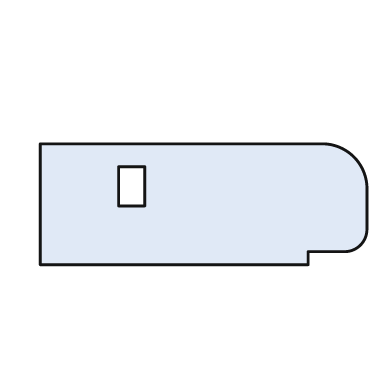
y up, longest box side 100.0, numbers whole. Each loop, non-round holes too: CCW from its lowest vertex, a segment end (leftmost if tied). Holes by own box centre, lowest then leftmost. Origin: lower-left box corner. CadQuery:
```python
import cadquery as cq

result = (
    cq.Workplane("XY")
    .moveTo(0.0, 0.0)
    .lineTo(82.0, 0.0)
    .lineTo(82.0, 4.0)
    .lineTo(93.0, 4.0)
    .threePointArc((98.0, 6.0), (100.0, 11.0))
    .lineTo(100.0, 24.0)
    .threePointArc((96.0, 33.0), (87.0, 37.0))
    .lineTo(0.0, 37.0)
    .close()
    .moveTo(24.0, 18.0)
    .lineTo(32.0, 18.0)
    .lineTo(32.0, 30.0)
    .lineTo(24.0, 30.0)
    .close()
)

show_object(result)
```